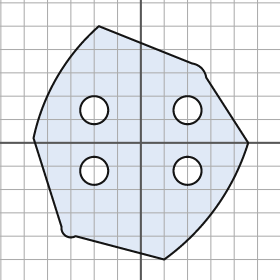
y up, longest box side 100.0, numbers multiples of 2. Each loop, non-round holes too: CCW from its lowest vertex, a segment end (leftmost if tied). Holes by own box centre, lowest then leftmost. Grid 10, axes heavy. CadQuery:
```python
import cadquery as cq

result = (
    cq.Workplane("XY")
    .moveTo(10.0, -50.0)
    .threePointArc((32.0, -28.0), (46.0, 0.0))
    .lineTo(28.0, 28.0)
    .threePointArc((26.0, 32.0), (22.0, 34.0))
    .lineTo(-18.0, 50.0)
    .threePointArc((-36.0, 28.0), (-46.0, 2.0))
    .lineTo(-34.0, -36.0)
    .threePointArc((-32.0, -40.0), (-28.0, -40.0))
    .close()
    .moveTo(-20.0, -12.0)
    .circle(6.0)
    .moveTo(20.0, -12.0)
    .circle(6.0)
    .moveTo(-20.0, 14.0)
    .circle(6.0)
    .moveTo(20.0, 14.0)
    .circle(6.0)
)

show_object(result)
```